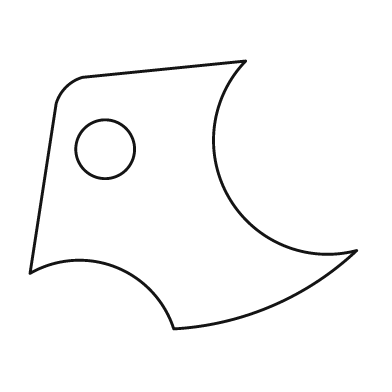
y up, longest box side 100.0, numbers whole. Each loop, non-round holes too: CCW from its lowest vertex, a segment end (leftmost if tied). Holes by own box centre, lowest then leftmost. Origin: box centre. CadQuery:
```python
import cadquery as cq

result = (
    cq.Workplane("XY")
    .moveTo(-6.0, -41.0)
    .threePointArc((24.0, -34.0), (50.0, -17.0))
    .threePointArc((11.0, -1.0), (16.0, 41.0))
    .lineTo(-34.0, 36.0)
    .threePointArc((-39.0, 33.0), (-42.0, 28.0))
    .lineTo(-50.0, -24.0)
    .threePointArc((-24.0, -22.0), (-6.0, -41.0))
    .close()
    .moveTo(-27.0, 14.0)
    .circle(9.0)
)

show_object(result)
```